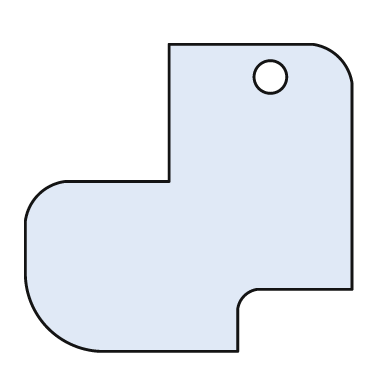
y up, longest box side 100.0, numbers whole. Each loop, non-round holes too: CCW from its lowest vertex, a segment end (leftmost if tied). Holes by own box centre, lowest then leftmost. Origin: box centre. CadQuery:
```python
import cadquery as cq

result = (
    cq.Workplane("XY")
    .moveTo(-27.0, -47.0)
    .lineTo(15.0, -47.0)
    .lineTo(15.0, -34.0)
    .threePointArc((17.0, -30.0), (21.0, -28.0))
    .lineTo(50.0, -28.0)
    .lineTo(50.0, 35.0)
    .threePointArc((46.0, 43.0), (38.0, 47.0))
    .lineTo(-6.0, 47.0)
    .lineTo(-6.0, 5.0)
    .lineTo(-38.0, 5.0)
    .threePointArc((-46.0, 1.0), (-50.0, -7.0))
    .lineTo(-50.0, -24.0)
    .threePointArc((-43.0, -40.0), (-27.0, -47.0))
    .close()
    .moveTo(25.0, 37.0)
    .circle(5.0)
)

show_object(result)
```